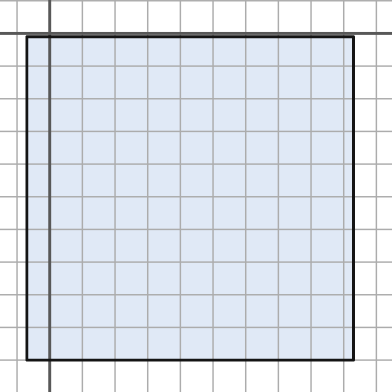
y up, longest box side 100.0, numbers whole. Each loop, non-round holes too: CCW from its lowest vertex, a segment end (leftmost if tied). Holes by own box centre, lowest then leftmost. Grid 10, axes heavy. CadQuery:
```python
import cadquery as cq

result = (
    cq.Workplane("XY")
    .moveTo(-7.0, -100.0)
    .lineTo(93.0, -100.0)
    .lineTo(93.0, -1.0)
    .lineTo(-7.0, -1.0)
    .close()
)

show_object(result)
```